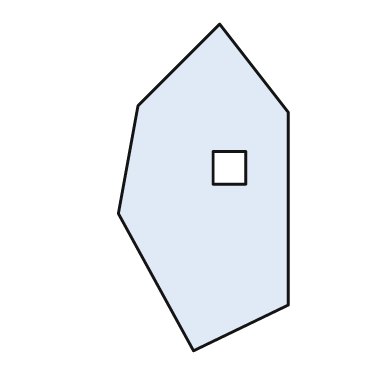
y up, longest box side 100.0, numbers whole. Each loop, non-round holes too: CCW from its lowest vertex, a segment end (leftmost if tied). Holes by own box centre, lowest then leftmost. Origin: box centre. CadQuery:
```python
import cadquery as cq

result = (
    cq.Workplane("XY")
    .moveTo(-3.0, -50.0)
    .lineTo(26.0, -36.0)
    .lineTo(26.0, 23.0)
    .lineTo(5.0, 50.0)
    .lineTo(-20.0, 25.0)
    .lineTo(-26.0, -8.0)
    .close()
    .moveTo(3.0, 1.0)
    .lineTo(13.0, 1.0)
    .lineTo(13.0, 11.0)
    .lineTo(3.0, 11.0)
    .close()
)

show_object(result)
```